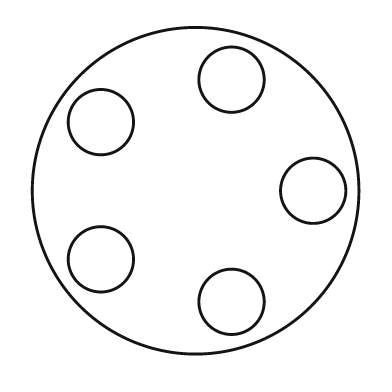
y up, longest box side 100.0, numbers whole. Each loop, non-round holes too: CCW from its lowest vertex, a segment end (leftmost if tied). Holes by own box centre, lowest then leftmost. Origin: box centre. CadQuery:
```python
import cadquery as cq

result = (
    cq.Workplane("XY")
    .moveTo(0.0, 0.0)
    .circle(50.0)
    .moveTo(11.0, -34.0)
    .circle(10.0)
    .moveTo(-29.0, -21.0)
    .circle(10.0)
    .moveTo(36.0, 0.0)
    .circle(10.0)
    .moveTo(-29.0, 21.0)
    .circle(10.0)
    .moveTo(11.0, 34.0)
    .circle(10.0)
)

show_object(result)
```